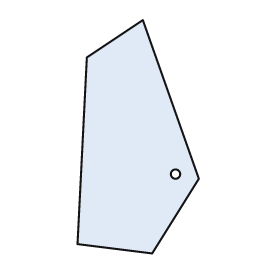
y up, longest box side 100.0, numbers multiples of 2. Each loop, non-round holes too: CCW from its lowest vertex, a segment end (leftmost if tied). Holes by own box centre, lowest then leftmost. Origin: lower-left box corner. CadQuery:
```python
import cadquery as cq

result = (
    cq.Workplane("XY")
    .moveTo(32.0, 0.0)
    .lineTo(52.0, 32.0)
    .lineTo(28.0, 100.0)
    .lineTo(4.0, 84.0)
    .lineTo(0.0, 4.0)
    .close()
    .moveTo(42.0, 34.0)
    .circle(2.0)
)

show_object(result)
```